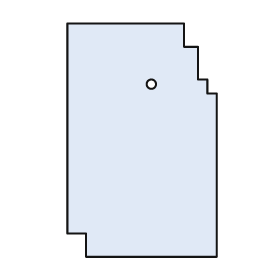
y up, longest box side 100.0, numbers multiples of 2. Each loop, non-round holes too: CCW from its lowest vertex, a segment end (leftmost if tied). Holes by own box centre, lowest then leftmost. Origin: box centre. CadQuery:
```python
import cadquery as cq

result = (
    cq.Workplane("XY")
    .moveTo(-24.0, -50.0)
    .lineTo(32.0, -50.0)
    .lineTo(32.0, 20.0)
    .lineTo(28.0, 20.0)
    .lineTo(28.0, 26.0)
    .lineTo(24.0, 26.0)
    .lineTo(24.0, 40.0)
    .lineTo(18.0, 40.0)
    .lineTo(18.0, 50.0)
    .lineTo(-32.0, 50.0)
    .lineTo(-32.0, -40.0)
    .lineTo(-24.0, -40.0)
    .close()
    .moveTo(4.0, 24.0)
    .circle(2.0)
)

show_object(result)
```